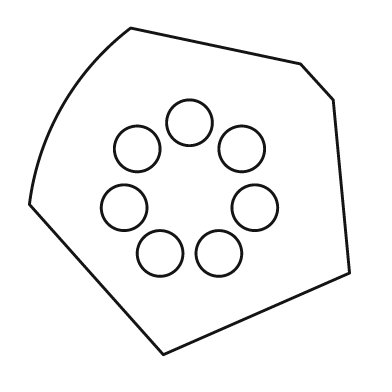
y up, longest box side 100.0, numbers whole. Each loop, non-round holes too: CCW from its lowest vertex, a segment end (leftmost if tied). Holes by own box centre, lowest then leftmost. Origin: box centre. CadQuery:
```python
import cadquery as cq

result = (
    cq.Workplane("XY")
    .moveTo(-8.0, -50.0)
    .lineTo(49.0, -25.0)
    .lineTo(44.0, 28.0)
    .lineTo(34.0, 39.0)
    .lineTo(-18.0, 50.0)
    .threePointArc((-39.0, 26.0), (-49.0, -4.0))
    .close()
    .moveTo(-9.0, -19.0)
    .circle(7.0)
    .moveTo(9.0, -19.0)
    .circle(7.0)
    .moveTo(-20.0, -5.0)
    .circle(7.0)
    .moveTo(20.0, -5.0)
    .circle(7.0)
    .moveTo(-16.0, 13.0)
    .circle(7.0)
    .moveTo(16.0, 13.0)
    .circle(7.0)
    .moveTo(0.0, 21.0)
    .circle(7.0)
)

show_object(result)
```